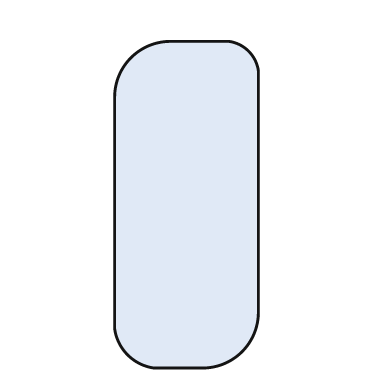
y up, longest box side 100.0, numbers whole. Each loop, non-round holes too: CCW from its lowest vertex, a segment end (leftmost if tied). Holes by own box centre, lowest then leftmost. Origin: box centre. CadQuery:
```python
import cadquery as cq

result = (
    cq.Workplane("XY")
    .moveTo(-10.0, -50.0)
    .lineTo(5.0, -50.0)
    .threePointArc((17.0, -45.0), (22.0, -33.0))
    .lineTo(22.0, 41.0)
    .threePointArc((19.0, 47.0), (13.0, 50.0))
    .lineTo(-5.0, 50.0)
    .threePointArc((-17.0, 45.0), (-22.0, 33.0))
    .lineTo(-22.0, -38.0)
    .threePointArc((-18.0, -46.0), (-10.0, -50.0))
    .close()
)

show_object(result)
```